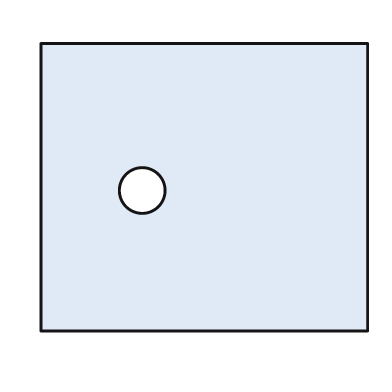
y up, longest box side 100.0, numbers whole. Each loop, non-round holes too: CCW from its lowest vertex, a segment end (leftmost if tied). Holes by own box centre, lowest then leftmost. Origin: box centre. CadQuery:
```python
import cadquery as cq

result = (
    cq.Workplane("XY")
    .moveTo(-50.0, -44.0)
    .lineTo(50.0, -44.0)
    .lineTo(50.0, 44.0)
    .lineTo(-50.0, 44.0)
    .close()
    .moveTo(-19.0, -1.0)
    .circle(7.0)
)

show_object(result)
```